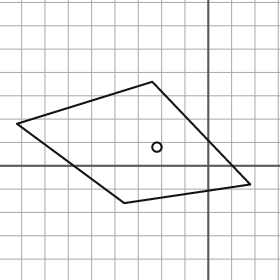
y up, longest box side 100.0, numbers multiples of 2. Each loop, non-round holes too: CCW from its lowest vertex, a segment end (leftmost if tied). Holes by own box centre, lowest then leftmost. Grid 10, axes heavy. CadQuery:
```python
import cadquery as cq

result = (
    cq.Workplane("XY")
    .moveTo(-36.0, -16.0)
    .lineTo(18.0, -8.0)
    .lineTo(-24.0, 36.0)
    .lineTo(-82.0, 18.0)
    .close()
    .moveTo(-22.0, 8.0)
    .circle(2.0)
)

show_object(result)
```